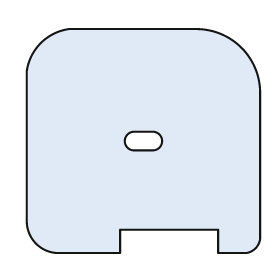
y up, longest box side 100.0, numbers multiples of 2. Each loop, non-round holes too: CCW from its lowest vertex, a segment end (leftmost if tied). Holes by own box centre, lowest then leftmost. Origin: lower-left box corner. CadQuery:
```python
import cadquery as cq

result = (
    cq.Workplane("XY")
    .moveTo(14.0, 0.0)
    .lineTo(40.0, 0.0)
    .lineTo(40.0, 10.0)
    .lineTo(82.0, 10.0)
    .lineTo(82.0, 0.0)
    .lineTo(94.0, 0.0)
    .threePointArc((98.0, 2.0), (100.0, 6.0))
    .lineTo(100.0, 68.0)
    .threePointArc((92.0, 88.0), (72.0, 96.0))
    .lineTo(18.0, 96.0)
    .threePointArc((6.0, 90.0), (0.0, 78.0))
    .lineTo(0.0, 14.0)
    .threePointArc((4.0, 4.0), (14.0, 0.0))
    .close()
    .moveTo(46.0, 44.0)
    .lineTo(54.0, 44.0)
    .threePointArc((58.0, 48.0), (54.0, 52.0))
    .lineTo(46.0, 52.0)
    .threePointArc((42.0, 48.0), (46.0, 44.0))
    .close()
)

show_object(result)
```